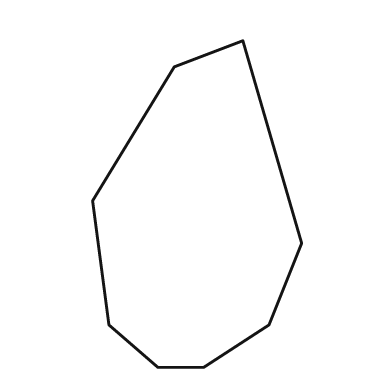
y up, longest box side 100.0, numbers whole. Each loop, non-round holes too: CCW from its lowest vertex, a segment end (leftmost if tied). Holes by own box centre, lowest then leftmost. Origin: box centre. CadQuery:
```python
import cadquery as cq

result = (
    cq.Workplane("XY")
    .moveTo(-12.0, -50.0)
    .lineTo(2.0, -50.0)
    .lineTo(22.0, -37.0)
    .lineTo(32.0, -12.0)
    .lineTo(14.0, 50.0)
    .lineTo(-7.0, 42.0)
    .lineTo(-32.0, 1.0)
    .lineTo(-27.0, -37.0)
    .close()
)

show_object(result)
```